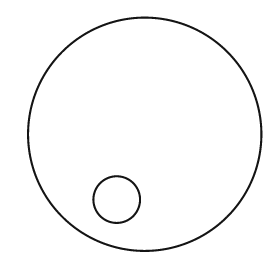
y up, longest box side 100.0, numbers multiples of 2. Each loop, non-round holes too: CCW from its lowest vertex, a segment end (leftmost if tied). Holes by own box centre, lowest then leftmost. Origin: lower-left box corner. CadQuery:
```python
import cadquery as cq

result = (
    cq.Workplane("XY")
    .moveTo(50.0, 50.0)
    .circle(50.0)
    .moveTo(38.0, 22.0)
    .circle(10.0)
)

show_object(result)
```